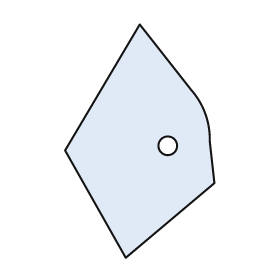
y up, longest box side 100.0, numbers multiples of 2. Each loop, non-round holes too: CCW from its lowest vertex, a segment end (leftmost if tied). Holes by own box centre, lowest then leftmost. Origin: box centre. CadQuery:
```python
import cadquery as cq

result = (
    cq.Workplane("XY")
    .moveTo(-6.0, -50.0)
    .lineTo(32.0, -18.0)
    .lineTo(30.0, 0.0)
    .threePointArc((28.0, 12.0), (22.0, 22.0))
    .lineTo(0.0, 50.0)
    .lineTo(-32.0, -4.0)
    .close()
    .moveTo(12.0, -2.0)
    .circle(4.0)
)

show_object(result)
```